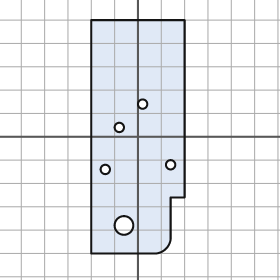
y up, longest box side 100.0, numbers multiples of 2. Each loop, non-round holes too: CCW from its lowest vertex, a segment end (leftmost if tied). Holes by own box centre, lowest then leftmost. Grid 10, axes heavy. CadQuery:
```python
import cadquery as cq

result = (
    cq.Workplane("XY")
    .moveTo(-20.0, -50.0)
    .lineTo(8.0, -50.0)
    .threePointArc((12.0, -48.0), (14.0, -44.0))
    .lineTo(14.0, -26.0)
    .lineTo(20.0, -26.0)
    .lineTo(20.0, 50.0)
    .lineTo(-20.0, 50.0)
    .close()
    .moveTo(-6.0, -38.0)
    .circle(4.0)
    .moveTo(-14.0, -14.0)
    .circle(2.0)
    .moveTo(14.0, -12.0)
    .circle(2.0)
    .moveTo(-8.0, 4.0)
    .circle(2.0)
    .moveTo(2.0, 14.0)
    .circle(2.0)
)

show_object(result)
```